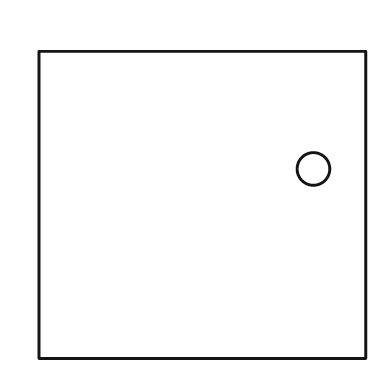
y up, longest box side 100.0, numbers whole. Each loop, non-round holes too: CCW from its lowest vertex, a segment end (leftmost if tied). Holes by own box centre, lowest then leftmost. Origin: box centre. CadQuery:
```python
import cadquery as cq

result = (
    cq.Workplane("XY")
    .moveTo(-50.0, -47.0)
    .lineTo(50.0, -47.0)
    .lineTo(50.0, 47.0)
    .lineTo(-50.0, 47.0)
    .close()
    .moveTo(34.0, 11.0)
    .circle(5.0)
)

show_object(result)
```